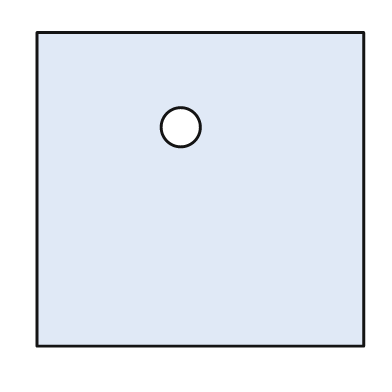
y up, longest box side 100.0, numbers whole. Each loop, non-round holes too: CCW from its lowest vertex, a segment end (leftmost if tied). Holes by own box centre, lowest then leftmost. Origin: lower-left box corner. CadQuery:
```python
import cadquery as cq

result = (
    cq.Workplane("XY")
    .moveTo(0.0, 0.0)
    .lineTo(100.0, 0.0)
    .lineTo(100.0, 96.0)
    .lineTo(0.0, 96.0)
    .close()
    .moveTo(44.0, 67.0)
    .circle(6.0)
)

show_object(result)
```